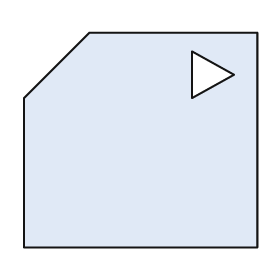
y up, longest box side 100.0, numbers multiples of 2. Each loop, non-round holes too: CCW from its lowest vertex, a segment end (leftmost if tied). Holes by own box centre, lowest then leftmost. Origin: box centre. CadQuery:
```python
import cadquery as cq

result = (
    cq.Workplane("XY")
    .moveTo(-50.0, -46.0)
    .lineTo(50.0, -46.0)
    .lineTo(50.0, 46.0)
    .lineTo(-22.0, 46.0)
    .lineTo(-50.0, 18.0)
    .close()
    .moveTo(22.0, 18.0)
    .lineTo(40.0, 28.0)
    .lineTo(22.0, 38.0)
    .close()
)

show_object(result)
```